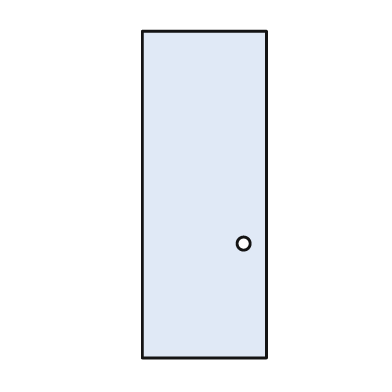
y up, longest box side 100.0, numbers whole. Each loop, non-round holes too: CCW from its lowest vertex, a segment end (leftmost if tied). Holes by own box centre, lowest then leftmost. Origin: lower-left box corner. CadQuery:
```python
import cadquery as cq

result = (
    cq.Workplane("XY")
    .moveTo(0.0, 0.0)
    .lineTo(38.0, 0.0)
    .lineTo(38.0, 100.0)
    .lineTo(0.0, 100.0)
    .close()
    .moveTo(31.0, 35.0)
    .circle(2.0)
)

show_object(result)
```